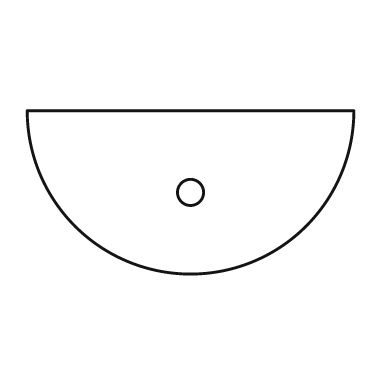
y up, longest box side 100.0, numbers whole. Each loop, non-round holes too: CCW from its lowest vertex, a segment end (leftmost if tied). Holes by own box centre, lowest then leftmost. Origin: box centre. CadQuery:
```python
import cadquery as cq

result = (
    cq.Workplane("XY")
    .moveTo(-50.0, 25.0)
    .threePointArc((0.0, -25.0), (50.0, 25.0))
    .close()
    .moveTo(0.0, 0.0)
    .circle(4.0)
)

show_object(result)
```